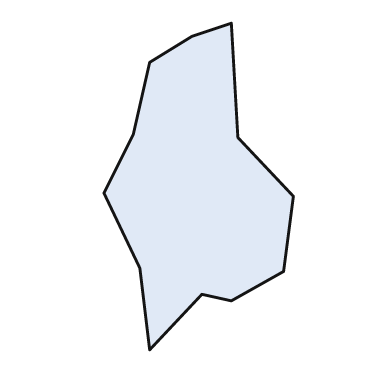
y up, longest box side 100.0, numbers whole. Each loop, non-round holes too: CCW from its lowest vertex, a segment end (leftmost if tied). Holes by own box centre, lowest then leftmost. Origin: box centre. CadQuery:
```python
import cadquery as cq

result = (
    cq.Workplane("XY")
    .moveTo(-15.0, -50.0)
    .lineTo(1.0, -33.0)
    .lineTo(10.0, -35.0)
    .lineTo(26.0, -26.0)
    .lineTo(29.0, -3.0)
    .lineTo(12.0, 15.0)
    .lineTo(10.0, 50.0)
    .lineTo(-2.0, 46.0)
    .lineTo(-15.0, 38.0)
    .lineTo(-20.0, 16.0)
    .lineTo(-29.0, -2.0)
    .lineTo(-18.0, -25.0)
    .close()
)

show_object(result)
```